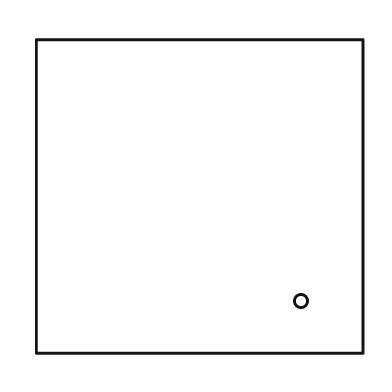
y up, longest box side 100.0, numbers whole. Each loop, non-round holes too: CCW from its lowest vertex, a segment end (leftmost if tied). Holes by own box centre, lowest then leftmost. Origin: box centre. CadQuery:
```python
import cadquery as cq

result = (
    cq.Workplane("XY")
    .moveTo(-50.0, -48.0)
    .lineTo(50.0, -48.0)
    .lineTo(50.0, 48.0)
    .lineTo(-50.0, 48.0)
    .close()
    .moveTo(31.0, -32.0)
    .circle(2.0)
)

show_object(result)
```